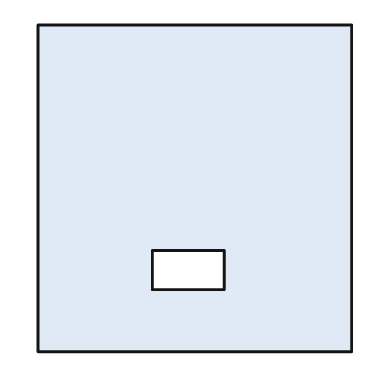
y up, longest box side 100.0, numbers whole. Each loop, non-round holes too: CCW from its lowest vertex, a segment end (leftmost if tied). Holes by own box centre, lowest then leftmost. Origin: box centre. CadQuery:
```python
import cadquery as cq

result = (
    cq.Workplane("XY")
    .moveTo(-48.0, -50.0)
    .lineTo(48.0, -50.0)
    .lineTo(48.0, 50.0)
    .lineTo(-48.0, 50.0)
    .close()
    .moveTo(-13.0, -31.0)
    .lineTo(9.0, -31.0)
    .lineTo(9.0, -19.0)
    .lineTo(-13.0, -19.0)
    .close()
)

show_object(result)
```